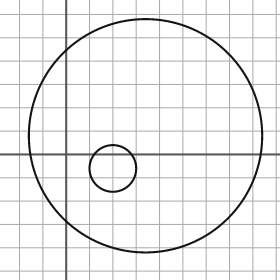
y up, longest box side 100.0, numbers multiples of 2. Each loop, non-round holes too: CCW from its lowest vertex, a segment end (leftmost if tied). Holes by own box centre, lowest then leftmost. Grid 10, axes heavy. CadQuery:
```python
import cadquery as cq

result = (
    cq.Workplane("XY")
    .moveTo(34.0, 8.0)
    .circle(50.0)
    .moveTo(20.0, -6.0)
    .circle(10.0)
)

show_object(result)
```